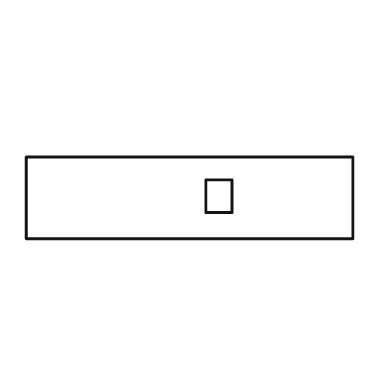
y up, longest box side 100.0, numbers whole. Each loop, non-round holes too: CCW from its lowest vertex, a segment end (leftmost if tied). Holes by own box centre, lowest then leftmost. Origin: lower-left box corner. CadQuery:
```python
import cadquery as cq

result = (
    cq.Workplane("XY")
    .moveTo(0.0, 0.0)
    .lineTo(100.0, 0.0)
    .lineTo(100.0, 25.0)
    .lineTo(0.0, 25.0)
    .close()
    .moveTo(55.0, 8.0)
    .lineTo(63.0, 8.0)
    .lineTo(63.0, 18.0)
    .lineTo(55.0, 18.0)
    .close()
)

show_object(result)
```